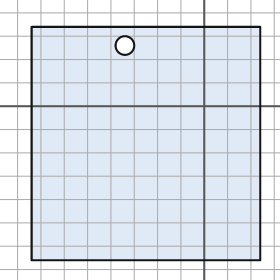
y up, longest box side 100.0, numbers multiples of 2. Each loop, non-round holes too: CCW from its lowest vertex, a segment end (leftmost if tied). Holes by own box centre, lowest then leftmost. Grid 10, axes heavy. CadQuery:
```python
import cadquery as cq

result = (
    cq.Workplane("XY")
    .moveTo(-74.0, -66.0)
    .lineTo(24.0, -66.0)
    .lineTo(24.0, 34.0)
    .lineTo(-74.0, 34.0)
    .close()
    .moveTo(-34.0, 26.0)
    .circle(4.0)
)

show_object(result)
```